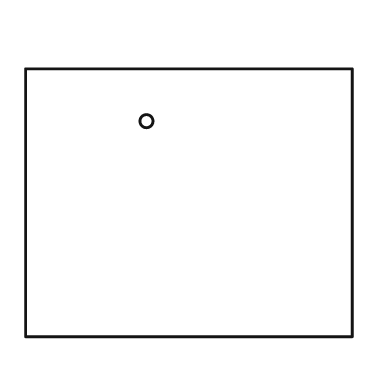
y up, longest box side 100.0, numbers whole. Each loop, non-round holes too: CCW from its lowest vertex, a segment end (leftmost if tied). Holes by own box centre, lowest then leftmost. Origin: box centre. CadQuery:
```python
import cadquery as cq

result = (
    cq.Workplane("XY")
    .moveTo(-50.0, -41.0)
    .lineTo(50.0, -41.0)
    .lineTo(50.0, 41.0)
    .lineTo(-50.0, 41.0)
    .close()
    .moveTo(-13.0, 25.0)
    .circle(2.0)
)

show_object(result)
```